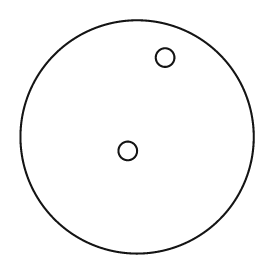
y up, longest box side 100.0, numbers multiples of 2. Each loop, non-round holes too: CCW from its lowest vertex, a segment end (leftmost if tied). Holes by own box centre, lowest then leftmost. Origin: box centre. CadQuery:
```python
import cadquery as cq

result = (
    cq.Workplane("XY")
    .moveTo(0.0, 0.0)
    .circle(50.0)
    .moveTo(-4.0, -6.0)
    .circle(4.0)
    .moveTo(12.0, 34.0)
    .circle(4.0)
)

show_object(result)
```